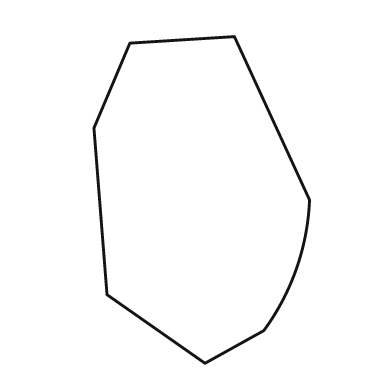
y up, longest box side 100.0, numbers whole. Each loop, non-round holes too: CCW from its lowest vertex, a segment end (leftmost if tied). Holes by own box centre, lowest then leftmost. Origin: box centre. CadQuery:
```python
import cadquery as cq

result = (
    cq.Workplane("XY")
    .moveTo(1.0, -50.0)
    .lineTo(19.0, -40.0)
    .threePointArc((29.0, -21.0), (33.0, 0.0))
    .lineTo(10.0, 50.0)
    .lineTo(-22.0, 48.0)
    .lineTo(-33.0, 22.0)
    .lineTo(-29.0, -29.0)
    .close()
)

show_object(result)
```